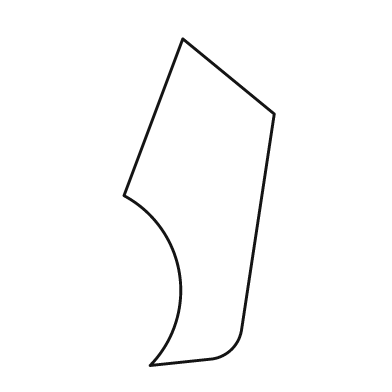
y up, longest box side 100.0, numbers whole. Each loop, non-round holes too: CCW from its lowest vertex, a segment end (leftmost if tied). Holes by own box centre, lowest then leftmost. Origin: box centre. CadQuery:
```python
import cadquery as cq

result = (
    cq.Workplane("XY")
    .moveTo(-15.0, -50.0)
    .lineTo(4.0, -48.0)
    .threePointArc((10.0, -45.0), (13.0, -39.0))
    .lineTo(23.0, 27.0)
    .lineTo(-5.0, 50.0)
    .lineTo(-23.0, 2.0)
    .threePointArc((-6.0, -22.0), (-15.0, -50.0))
    .close()
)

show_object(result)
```